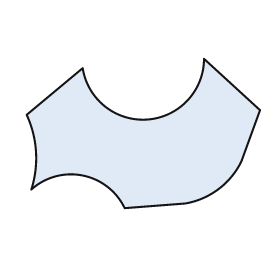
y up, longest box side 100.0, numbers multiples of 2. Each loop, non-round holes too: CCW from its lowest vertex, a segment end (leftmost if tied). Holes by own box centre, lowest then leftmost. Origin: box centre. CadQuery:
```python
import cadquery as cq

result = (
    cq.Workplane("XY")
    .moveTo(-8.0, -32.0)
    .lineTo(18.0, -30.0)
    .threePointArc((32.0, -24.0), (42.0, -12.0))
    .lineTo(50.0, 10.0)
    .lineTo(26.0, 32.0)
    .threePointArc((2.0, 6.0), (-26.0, 28.0))
    .lineTo(-50.0, 8.0)
    .threePointArc((-46.0, -8.0), (-48.0, -24.0))
    .threePointArc((-26.0, -18.0), (-8.0, -32.0))
    .close()
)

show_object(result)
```